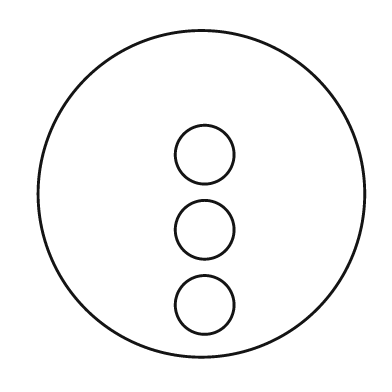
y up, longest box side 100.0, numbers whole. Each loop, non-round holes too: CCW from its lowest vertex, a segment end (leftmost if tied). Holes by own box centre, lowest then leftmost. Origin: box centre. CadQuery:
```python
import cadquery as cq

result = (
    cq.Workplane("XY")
    .moveTo(0.0, 0.0)
    .circle(50.0)
    .moveTo(1.0, -34.0)
    .circle(9.0)
    .moveTo(1.0, -11.0)
    .circle(9.0)
    .moveTo(1.0, 12.0)
    .circle(9.0)
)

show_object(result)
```